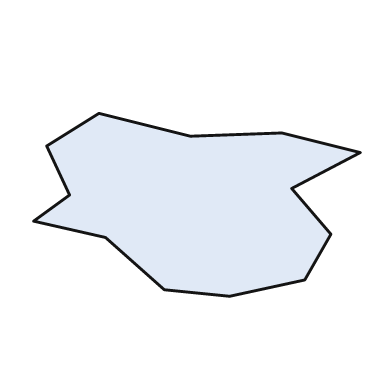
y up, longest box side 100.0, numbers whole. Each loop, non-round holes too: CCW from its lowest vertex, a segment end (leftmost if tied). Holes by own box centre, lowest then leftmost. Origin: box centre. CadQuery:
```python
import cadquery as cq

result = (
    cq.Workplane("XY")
    .moveTo(10.0, -28.0)
    .lineTo(33.0, -23.0)
    .lineTo(41.0, -9.0)
    .lineTo(29.0, 5.0)
    .lineTo(50.0, 16.0)
    .lineTo(26.0, 22.0)
    .lineTo(-2.0, 21.0)
    .lineTo(-30.0, 28.0)
    .lineTo(-46.0, 18.0)
    .lineTo(-39.0, 3.0)
    .lineTo(-50.0, -5.0)
    .lineTo(-28.0, -10.0)
    .lineTo(-10.0, -26.0)
    .close()
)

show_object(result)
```